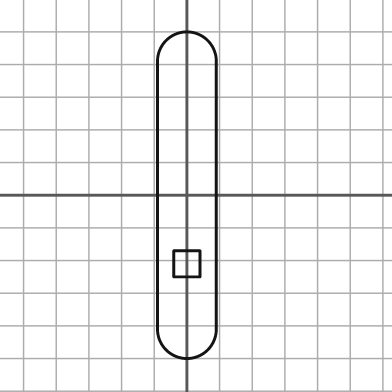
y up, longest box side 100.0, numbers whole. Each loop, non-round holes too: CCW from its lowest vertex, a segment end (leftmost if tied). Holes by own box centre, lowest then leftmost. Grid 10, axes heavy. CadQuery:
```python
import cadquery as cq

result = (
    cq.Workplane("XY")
    .moveTo(-9.0, -41.0)
    .threePointArc((0.0, -50.0), (9.0, -41.0))
    .lineTo(9.0, 41.0)
    .threePointArc((0.0, 50.0), (-9.0, 41.0))
    .close()
    .moveTo(-4.0, -25.0)
    .lineTo(4.0, -25.0)
    .lineTo(4.0, -17.0)
    .lineTo(-4.0, -17.0)
    .close()
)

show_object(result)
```